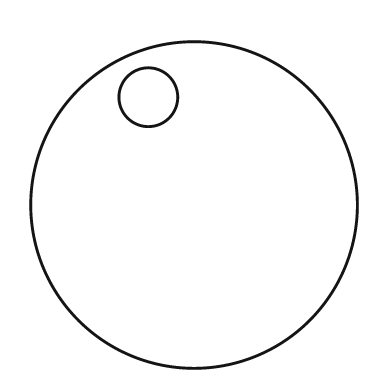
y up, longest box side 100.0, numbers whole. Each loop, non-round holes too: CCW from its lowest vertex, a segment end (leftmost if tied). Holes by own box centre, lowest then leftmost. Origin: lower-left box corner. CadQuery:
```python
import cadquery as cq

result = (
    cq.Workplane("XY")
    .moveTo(50.0, 50.0)
    .circle(50.0)
    .moveTo(36.0, 83.0)
    .circle(9.0)
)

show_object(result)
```